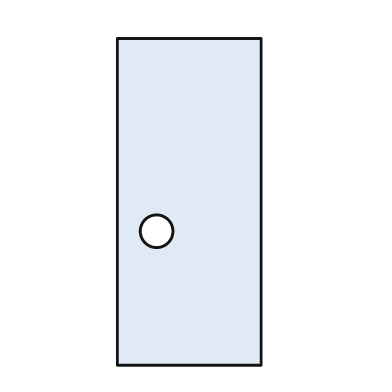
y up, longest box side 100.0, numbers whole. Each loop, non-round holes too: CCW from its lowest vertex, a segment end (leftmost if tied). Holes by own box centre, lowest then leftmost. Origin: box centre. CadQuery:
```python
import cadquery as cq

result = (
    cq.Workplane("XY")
    .moveTo(-22.0, -50.0)
    .lineTo(22.0, -50.0)
    .lineTo(22.0, 50.0)
    .lineTo(-22.0, 50.0)
    .close()
    .moveTo(-10.0, -9.0)
    .circle(5.0)
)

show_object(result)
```